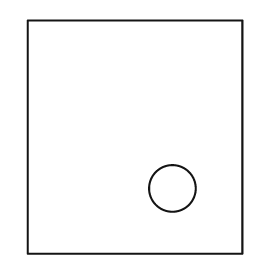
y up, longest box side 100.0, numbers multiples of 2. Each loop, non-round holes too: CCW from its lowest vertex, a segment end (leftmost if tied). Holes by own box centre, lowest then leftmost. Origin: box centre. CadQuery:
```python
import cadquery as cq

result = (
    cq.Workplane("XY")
    .moveTo(-46.0, -50.0)
    .lineTo(46.0, -50.0)
    .lineTo(46.0, 50.0)
    .lineTo(-46.0, 50.0)
    .close()
    .moveTo(16.0, -22.0)
    .circle(10.0)
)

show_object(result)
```